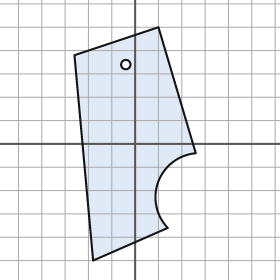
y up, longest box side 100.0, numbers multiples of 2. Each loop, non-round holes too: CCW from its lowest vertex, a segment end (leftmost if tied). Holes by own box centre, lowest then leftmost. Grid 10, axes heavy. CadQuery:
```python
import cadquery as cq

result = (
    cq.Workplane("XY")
    .moveTo(-18.0, -50.0)
    .lineTo(14.0, -36.0)
    .threePointArc((10.0, -16.0), (26.0, -4.0))
    .lineTo(10.0, 50.0)
    .lineTo(-26.0, 38.0)
    .close()
    .moveTo(-4.0, 34.0)
    .circle(2.0)
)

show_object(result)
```